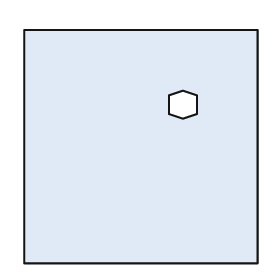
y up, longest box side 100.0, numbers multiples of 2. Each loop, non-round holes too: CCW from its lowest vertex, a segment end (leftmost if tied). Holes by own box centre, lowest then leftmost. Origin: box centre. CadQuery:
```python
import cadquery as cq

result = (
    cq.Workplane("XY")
    .moveTo(-50.0, -50.0)
    .lineTo(50.0, -50.0)
    .lineTo(50.0, 50.0)
    .lineTo(-50.0, 50.0)
    .close()
    .moveTo(18.0, 12.0)
    .lineTo(24.0, 14.0)
    .lineTo(24.0, 22.0)
    .lineTo(18.0, 24.0)
    .lineTo(12.0, 22.0)
    .lineTo(12.0, 14.0)
    .close()
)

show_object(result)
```